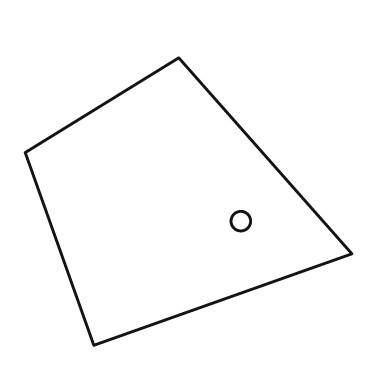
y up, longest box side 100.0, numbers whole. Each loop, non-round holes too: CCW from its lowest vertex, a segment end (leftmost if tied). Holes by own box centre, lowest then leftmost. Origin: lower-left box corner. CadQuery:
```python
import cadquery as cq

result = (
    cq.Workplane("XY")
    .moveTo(21.0, 0.0)
    .lineTo(100.0, 28.0)
    .lineTo(47.0, 88.0)
    .lineTo(0.0, 59.0)
    .close()
    .moveTo(66.0, 38.0)
    .circle(3.0)
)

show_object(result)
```